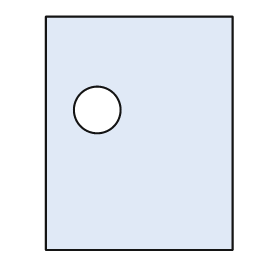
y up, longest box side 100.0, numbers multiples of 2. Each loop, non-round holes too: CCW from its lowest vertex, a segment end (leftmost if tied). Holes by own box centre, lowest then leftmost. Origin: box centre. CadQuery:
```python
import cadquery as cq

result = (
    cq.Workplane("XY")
    .moveTo(-40.0, -50.0)
    .lineTo(40.0, -50.0)
    .lineTo(40.0, 50.0)
    .lineTo(-40.0, 50.0)
    .close()
    .moveTo(-18.0, 10.0)
    .circle(10.0)
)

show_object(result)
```